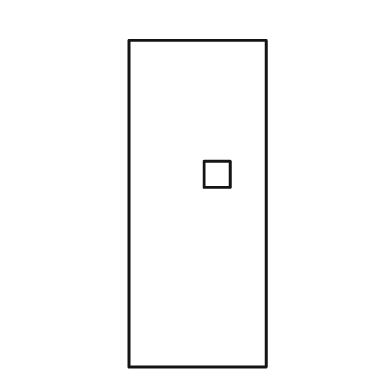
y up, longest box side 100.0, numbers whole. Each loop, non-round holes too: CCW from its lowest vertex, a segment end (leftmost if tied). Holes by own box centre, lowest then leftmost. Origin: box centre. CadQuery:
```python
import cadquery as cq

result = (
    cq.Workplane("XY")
    .moveTo(-21.0, -50.0)
    .lineTo(21.0, -50.0)
    .lineTo(21.0, 50.0)
    .lineTo(-21.0, 50.0)
    .close()
    .moveTo(2.0, 5.0)
    .lineTo(10.0, 5.0)
    .lineTo(10.0, 13.0)
    .lineTo(2.0, 13.0)
    .close()
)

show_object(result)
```